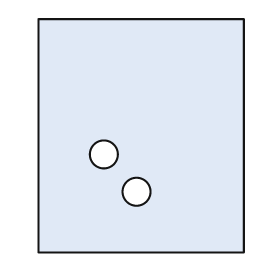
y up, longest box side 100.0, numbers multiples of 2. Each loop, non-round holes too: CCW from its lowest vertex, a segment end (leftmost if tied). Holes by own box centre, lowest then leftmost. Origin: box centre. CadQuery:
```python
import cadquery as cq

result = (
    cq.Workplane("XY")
    .moveTo(-44.0, -50.0)
    .lineTo(44.0, -50.0)
    .lineTo(44.0, 50.0)
    .lineTo(-44.0, 50.0)
    .close()
    .moveTo(-2.0, -24.0)
    .circle(6.0)
    .moveTo(-16.0, -8.0)
    .circle(6.0)
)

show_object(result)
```